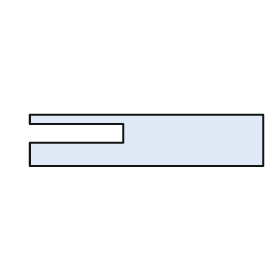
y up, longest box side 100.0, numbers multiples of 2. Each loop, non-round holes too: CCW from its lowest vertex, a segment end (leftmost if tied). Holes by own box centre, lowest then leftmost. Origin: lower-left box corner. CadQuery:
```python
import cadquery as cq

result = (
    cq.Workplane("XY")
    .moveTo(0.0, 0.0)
    .lineTo(100.0, 0.0)
    .lineTo(100.0, 22.0)
    .lineTo(0.0, 22.0)
    .lineTo(0.0, 18.0)
    .lineTo(40.0, 18.0)
    .lineTo(40.0, 10.0)
    .lineTo(0.0, 10.0)
    .close()
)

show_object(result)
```